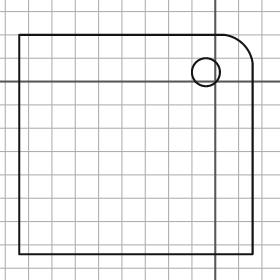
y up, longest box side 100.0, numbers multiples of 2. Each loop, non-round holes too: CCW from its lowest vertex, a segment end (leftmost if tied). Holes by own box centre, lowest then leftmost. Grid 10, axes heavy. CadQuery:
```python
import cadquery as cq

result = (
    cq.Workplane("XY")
    .moveTo(-84.0, -74.0)
    .lineTo(16.0, -74.0)
    .lineTo(16.0, 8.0)
    .threePointArc((12.0, 16.0), (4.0, 20.0))
    .lineTo(-84.0, 20.0)
    .close()
    .moveTo(-4.0, 4.0)
    .circle(6.0)
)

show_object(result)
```